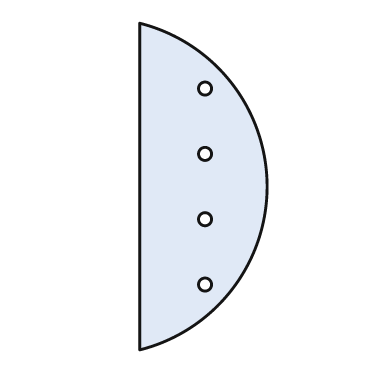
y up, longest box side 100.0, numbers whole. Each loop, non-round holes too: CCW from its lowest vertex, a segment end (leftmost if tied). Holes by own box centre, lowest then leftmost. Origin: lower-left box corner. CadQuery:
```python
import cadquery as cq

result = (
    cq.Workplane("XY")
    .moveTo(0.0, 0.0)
    .threePointArc((39.0, 50.0), (0.0, 100.0))
    .close()
    .moveTo(20.0, 20.0)
    .circle(2.0)
    .moveTo(20.0, 40.0)
    .circle(2.0)
    .moveTo(20.0, 60.0)
    .circle(2.0)
    .moveTo(20.0, 80.0)
    .circle(2.0)
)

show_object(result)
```